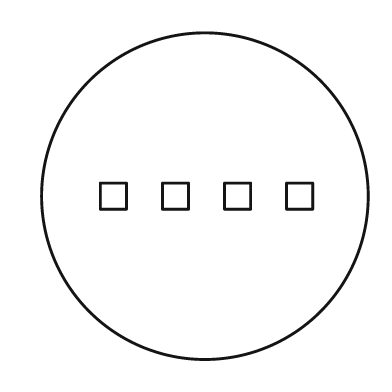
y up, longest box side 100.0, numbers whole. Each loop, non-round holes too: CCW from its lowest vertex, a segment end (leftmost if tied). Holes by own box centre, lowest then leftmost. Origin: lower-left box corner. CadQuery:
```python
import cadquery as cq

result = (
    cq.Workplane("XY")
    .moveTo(50.0, 50.0)
    .circle(50.0)
    .moveTo(18.0, 46.0)
    .lineTo(26.0, 46.0)
    .lineTo(26.0, 54.0)
    .lineTo(18.0, 54.0)
    .close()
    .moveTo(37.0, 46.0)
    .lineTo(45.0, 46.0)
    .lineTo(45.0, 54.0)
    .lineTo(37.0, 54.0)
    .close()
    .moveTo(56.0, 46.0)
    .lineTo(64.0, 46.0)
    .lineTo(64.0, 54.0)
    .lineTo(56.0, 54.0)
    .close()
    .moveTo(75.0, 46.0)
    .lineTo(83.0, 46.0)
    .lineTo(83.0, 54.0)
    .lineTo(75.0, 54.0)
    .close()
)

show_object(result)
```